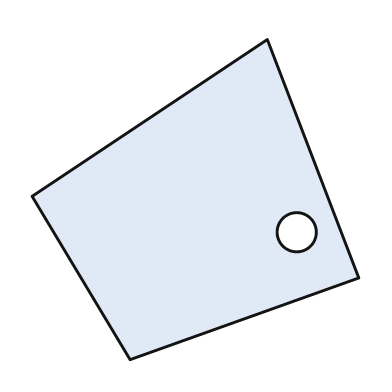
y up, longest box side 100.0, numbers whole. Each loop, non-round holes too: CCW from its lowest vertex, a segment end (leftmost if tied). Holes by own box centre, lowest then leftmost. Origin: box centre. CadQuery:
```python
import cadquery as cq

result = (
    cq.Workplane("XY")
    .moveTo(-20.0, -49.0)
    .lineTo(50.0, -24.0)
    .lineTo(22.0, 49.0)
    .lineTo(-50.0, 1.0)
    .close()
    .moveTo(31.0, -10.0)
    .circle(6.0)
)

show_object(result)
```